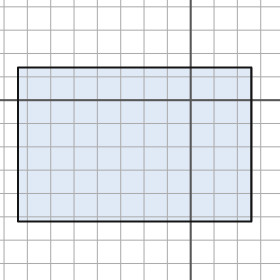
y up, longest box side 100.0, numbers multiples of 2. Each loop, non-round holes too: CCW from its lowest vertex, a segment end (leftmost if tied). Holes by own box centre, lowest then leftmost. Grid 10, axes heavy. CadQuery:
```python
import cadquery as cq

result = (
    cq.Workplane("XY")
    .moveTo(-74.0, -52.0)
    .lineTo(26.0, -52.0)
    .lineTo(26.0, 14.0)
    .lineTo(-74.0, 14.0)
    .close()
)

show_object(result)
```